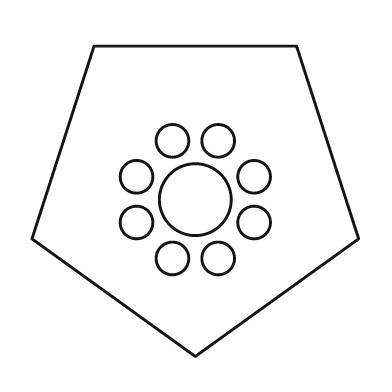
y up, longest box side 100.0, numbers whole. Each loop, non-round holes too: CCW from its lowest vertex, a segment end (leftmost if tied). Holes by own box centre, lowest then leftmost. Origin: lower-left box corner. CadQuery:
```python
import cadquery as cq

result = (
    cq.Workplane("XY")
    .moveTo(50.0, 0.0)
    .lineTo(100.0, 36.0)
    .lineTo(81.0, 95.0)
    .lineTo(19.0, 95.0)
    .lineTo(0.0, 36.0)
    .close()
    .moveTo(43.0, 30.0)
    .circle(5.0)
    .moveTo(57.0, 30.0)
    .circle(5.0)
    .moveTo(32.0, 41.0)
    .circle(5.0)
    .moveTo(68.0, 41.0)
    .circle(5.0)
    .moveTo(50.0, 48.0)
    .circle(11.0)
    .moveTo(32.0, 55.0)
    .circle(5.0)
    .moveTo(68.0, 55.0)
    .circle(5.0)
    .moveTo(43.0, 66.0)
    .circle(5.0)
    .moveTo(57.0, 66.0)
    .circle(5.0)
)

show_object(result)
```